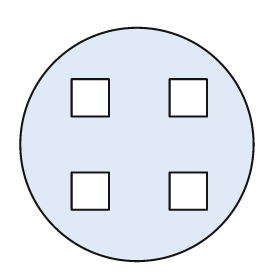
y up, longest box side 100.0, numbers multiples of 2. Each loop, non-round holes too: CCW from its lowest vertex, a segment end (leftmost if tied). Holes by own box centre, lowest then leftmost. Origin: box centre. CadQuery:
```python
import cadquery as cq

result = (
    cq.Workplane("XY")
    .moveTo(0.0, 0.0)
    .circle(50.0)
    .moveTo(-28.0, -28.0)
    .lineTo(-12.0, -28.0)
    .lineTo(-12.0, -12.0)
    .lineTo(-28.0, -12.0)
    .close()
    .moveTo(14.0, -28.0)
    .lineTo(30.0, -28.0)
    .lineTo(30.0, -12.0)
    .lineTo(14.0, -12.0)
    .close()
    .moveTo(-28.0, 12.0)
    .lineTo(-12.0, 12.0)
    .lineTo(-12.0, 28.0)
    .lineTo(-28.0, 28.0)
    .close()
    .moveTo(14.0, 12.0)
    .lineTo(30.0, 12.0)
    .lineTo(30.0, 28.0)
    .lineTo(14.0, 28.0)
    .close()
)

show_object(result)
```